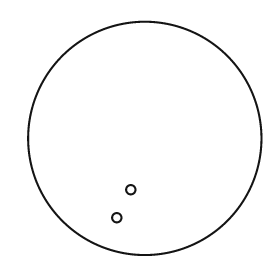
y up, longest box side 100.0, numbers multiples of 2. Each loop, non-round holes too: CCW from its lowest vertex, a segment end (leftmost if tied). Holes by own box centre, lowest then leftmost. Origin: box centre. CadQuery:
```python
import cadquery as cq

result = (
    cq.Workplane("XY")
    .moveTo(0.0, 0.0)
    .circle(50.0)
    .moveTo(-12.0, -34.0)
    .circle(2.0)
    .moveTo(-6.0, -22.0)
    .circle(2.0)
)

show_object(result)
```